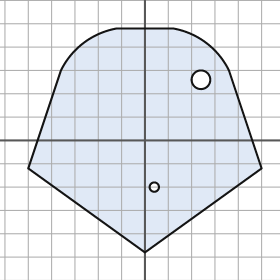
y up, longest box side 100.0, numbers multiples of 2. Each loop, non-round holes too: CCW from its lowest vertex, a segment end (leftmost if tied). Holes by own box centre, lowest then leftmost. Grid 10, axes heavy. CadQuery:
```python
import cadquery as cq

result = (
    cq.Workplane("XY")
    .moveTo(0.0, -48.0)
    .lineTo(50.0, -12.0)
    .lineTo(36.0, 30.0)
    .threePointArc((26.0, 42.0), (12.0, 48.0))
    .lineTo(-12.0, 48.0)
    .threePointArc((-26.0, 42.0), (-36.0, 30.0))
    .lineTo(-50.0, -12.0)
    .close()
    .moveTo(4.0, -20.0)
    .circle(2.0)
    .moveTo(24.0, 26.0)
    .circle(4.0)
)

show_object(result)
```